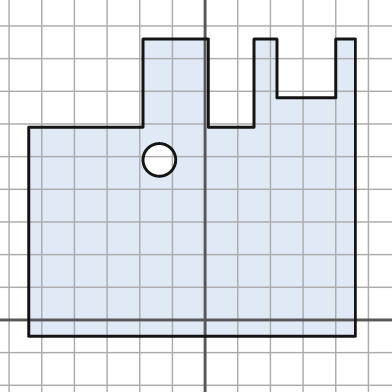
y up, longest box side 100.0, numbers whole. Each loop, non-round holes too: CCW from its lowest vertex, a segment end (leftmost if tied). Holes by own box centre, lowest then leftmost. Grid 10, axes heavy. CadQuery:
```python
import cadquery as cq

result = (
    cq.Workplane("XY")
    .moveTo(-54.0, -5.0)
    .lineTo(46.0, -5.0)
    .lineTo(46.0, 86.0)
    .lineTo(40.0, 86.0)
    .lineTo(40.0, 68.0)
    .lineTo(22.0, 68.0)
    .lineTo(22.0, 86.0)
    .lineTo(15.0, 86.0)
    .lineTo(15.0, 59.0)
    .lineTo(1.0, 59.0)
    .lineTo(1.0, 86.0)
    .lineTo(-19.0, 86.0)
    .lineTo(-19.0, 59.0)
    .lineTo(-54.0, 59.0)
    .close()
    .moveTo(-14.0, 49.0)
    .circle(5.0)
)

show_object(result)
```